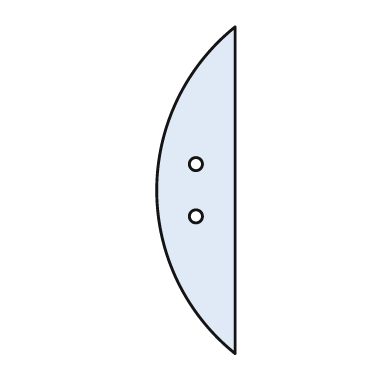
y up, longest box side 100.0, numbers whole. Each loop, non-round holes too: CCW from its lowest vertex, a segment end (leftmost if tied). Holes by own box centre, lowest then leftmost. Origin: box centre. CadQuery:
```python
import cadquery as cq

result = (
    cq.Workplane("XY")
    .moveTo(12.0, -50.0)
    .lineTo(12.0, 50.0)
    .threePointArc((-12.0, 0.0), (12.0, -50.0))
    .close()
    .moveTo(0.0, -8.0)
    .circle(2.0)
    .moveTo(0.0, 8.0)
    .circle(2.0)
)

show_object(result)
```